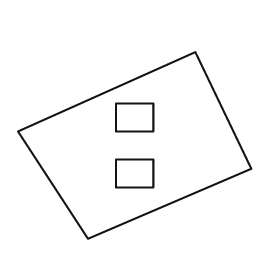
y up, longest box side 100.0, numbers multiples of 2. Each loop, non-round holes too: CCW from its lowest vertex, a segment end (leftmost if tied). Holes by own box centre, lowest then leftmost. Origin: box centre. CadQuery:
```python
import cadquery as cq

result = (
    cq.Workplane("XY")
    .moveTo(-20.0, -40.0)
    .lineTo(50.0, -10.0)
    .lineTo(26.0, 40.0)
    .lineTo(-50.0, 6.0)
    .close()
    .moveTo(-8.0, -18.0)
    .lineTo(8.0, -18.0)
    .lineTo(8.0, -6.0)
    .lineTo(-8.0, -6.0)
    .close()
    .moveTo(-8.0, 6.0)
    .lineTo(8.0, 6.0)
    .lineTo(8.0, 18.0)
    .lineTo(-8.0, 18.0)
    .close()
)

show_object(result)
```